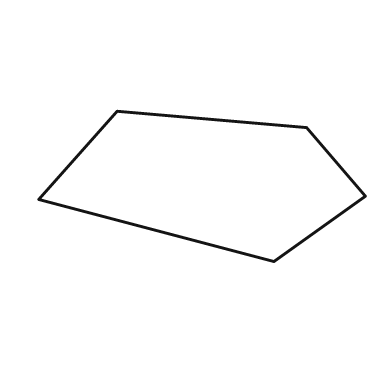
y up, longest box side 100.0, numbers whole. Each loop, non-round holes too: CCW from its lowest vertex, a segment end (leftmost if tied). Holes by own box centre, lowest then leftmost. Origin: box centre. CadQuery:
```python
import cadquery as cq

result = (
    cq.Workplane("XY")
    .moveTo(22.0, -23.0)
    .lineTo(50.0, -3.0)
    .lineTo(32.0, 18.0)
    .lineTo(-26.0, 23.0)
    .lineTo(-50.0, -4.0)
    .close()
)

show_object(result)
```